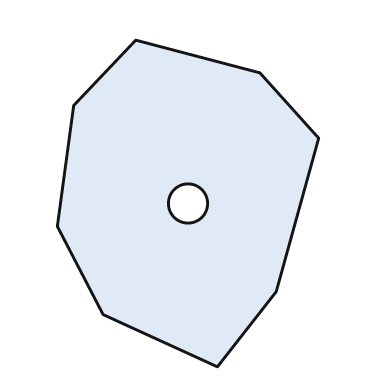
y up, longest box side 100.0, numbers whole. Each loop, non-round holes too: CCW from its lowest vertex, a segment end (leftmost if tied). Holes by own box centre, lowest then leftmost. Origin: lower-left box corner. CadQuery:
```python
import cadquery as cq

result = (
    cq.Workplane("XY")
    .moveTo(49.0, 0.0)
    .lineTo(67.0, 23.0)
    .lineTo(80.0, 70.0)
    .lineTo(62.0, 90.0)
    .lineTo(24.0, 100.0)
    .lineTo(5.0, 80.0)
    .lineTo(0.0, 43.0)
    .lineTo(14.0, 16.0)
    .close()
    .moveTo(40.0, 50.0)
    .circle(6.0)
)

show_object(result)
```